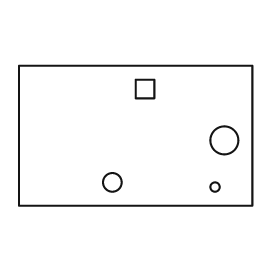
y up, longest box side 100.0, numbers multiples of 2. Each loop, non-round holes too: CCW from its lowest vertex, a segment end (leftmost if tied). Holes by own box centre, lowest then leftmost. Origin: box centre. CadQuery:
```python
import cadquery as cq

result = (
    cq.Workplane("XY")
    .moveTo(-50.0, -30.0)
    .lineTo(50.0, -30.0)
    .lineTo(50.0, 30.0)
    .lineTo(-50.0, 30.0)
    .close()
    .moveTo(34.0, -22.0)
    .circle(2.0)
    .moveTo(-10.0, -20.0)
    .circle(4.0)
    .moveTo(38.0, -2.0)
    .circle(6.0)
    .moveTo(0.0, 16.0)
    .lineTo(8.0, 16.0)
    .lineTo(8.0, 24.0)
    .lineTo(0.0, 24.0)
    .close()
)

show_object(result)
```